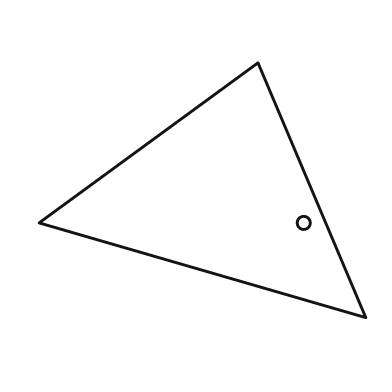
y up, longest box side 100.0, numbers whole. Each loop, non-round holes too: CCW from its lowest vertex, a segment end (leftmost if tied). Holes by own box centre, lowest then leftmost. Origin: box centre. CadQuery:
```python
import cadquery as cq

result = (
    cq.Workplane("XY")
    .moveTo(50.0, -39.0)
    .lineTo(17.0, 39.0)
    .lineTo(-50.0, -10.0)
    .close()
    .moveTo(31.0, -10.0)
    .circle(2.0)
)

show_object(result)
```